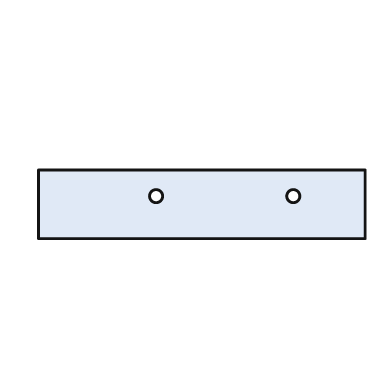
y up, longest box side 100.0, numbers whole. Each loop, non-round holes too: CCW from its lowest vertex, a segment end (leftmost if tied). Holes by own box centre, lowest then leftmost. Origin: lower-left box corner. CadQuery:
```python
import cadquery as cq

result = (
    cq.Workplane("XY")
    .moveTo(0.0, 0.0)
    .lineTo(100.0, 0.0)
    .lineTo(100.0, 21.0)
    .lineTo(0.0, 21.0)
    .close()
    .moveTo(36.0, 13.0)
    .circle(2.0)
    .moveTo(78.0, 13.0)
    .circle(2.0)
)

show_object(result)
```